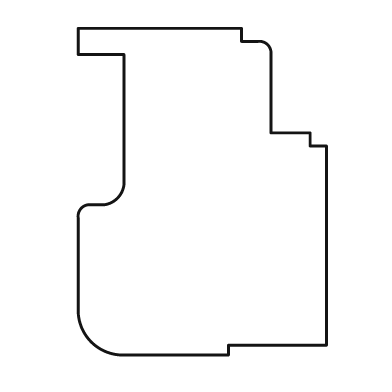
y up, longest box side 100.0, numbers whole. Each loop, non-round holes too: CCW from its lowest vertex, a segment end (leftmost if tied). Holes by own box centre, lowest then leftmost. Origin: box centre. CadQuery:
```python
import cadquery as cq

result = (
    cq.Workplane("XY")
    .moveTo(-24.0, -50.0)
    .lineTo(8.0, -50.0)
    .lineTo(8.0, -47.0)
    .lineTo(38.0, -47.0)
    .lineTo(38.0, 14.0)
    .lineTo(33.0, 14.0)
    .lineTo(33.0, 18.0)
    .lineTo(21.0, 18.0)
    .lineTo(21.0, 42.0)
    .threePointArc((20.0, 45.0), (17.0, 46.0))
    .lineTo(12.0, 46.0)
    .lineTo(12.0, 50.0)
    .lineTo(-38.0, 50.0)
    .lineTo(-38.0, 42.0)
    .lineTo(-24.0, 42.0)
    .lineTo(-24.0, 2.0)
    .threePointArc((-26.0, -2.0), (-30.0, -4.0))
    .lineTo(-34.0, -4.0)
    .threePointArc((-37.0, -5.0), (-38.0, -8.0))
    .lineTo(-38.0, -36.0)
    .threePointArc((-34.0, -46.0), (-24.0, -50.0))
    .close()
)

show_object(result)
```